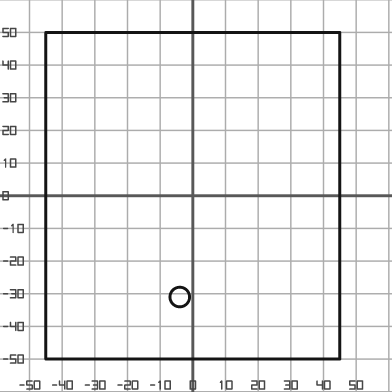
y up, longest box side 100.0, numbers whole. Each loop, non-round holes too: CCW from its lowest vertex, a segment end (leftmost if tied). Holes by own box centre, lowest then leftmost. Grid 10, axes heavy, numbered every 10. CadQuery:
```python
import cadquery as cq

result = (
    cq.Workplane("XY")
    .moveTo(-45.0, -50.0)
    .lineTo(45.0, -50.0)
    .lineTo(45.0, 50.0)
    .lineTo(-45.0, 50.0)
    .close()
    .moveTo(-4.0, -31.0)
    .circle(3.0)
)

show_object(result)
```